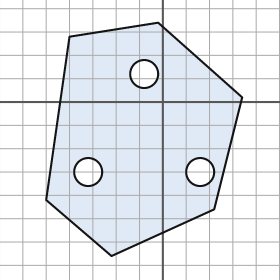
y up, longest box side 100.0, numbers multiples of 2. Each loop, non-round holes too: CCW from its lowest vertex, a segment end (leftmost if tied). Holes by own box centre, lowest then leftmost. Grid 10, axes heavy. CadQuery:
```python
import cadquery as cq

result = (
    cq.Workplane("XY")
    .moveTo(-22.0, -66.0)
    .lineTo(22.0, -46.0)
    .lineTo(34.0, 2.0)
    .lineTo(-2.0, 34.0)
    .lineTo(-40.0, 28.0)
    .lineTo(-50.0, -42.0)
    .close()
    .moveTo(-32.0, -30.0)
    .circle(6.0)
    .moveTo(16.0, -30.0)
    .circle(6.0)
    .moveTo(-8.0, 12.0)
    .circle(6.0)
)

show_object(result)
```